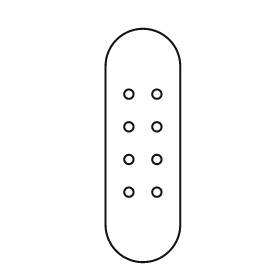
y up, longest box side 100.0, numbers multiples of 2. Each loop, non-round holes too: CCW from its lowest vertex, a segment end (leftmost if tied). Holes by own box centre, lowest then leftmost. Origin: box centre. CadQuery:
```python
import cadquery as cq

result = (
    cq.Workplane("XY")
    .moveTo(-16.0, -34.0)
    .threePointArc((0.0, -50.0), (16.0, -34.0))
    .lineTo(16.0, 34.0)
    .threePointArc((0.0, 50.0), (-16.0, 34.0))
    .close()
    .moveTo(-6.0, -20.0)
    .circle(2.0)
    .moveTo(6.0, -20.0)
    .circle(2.0)
    .moveTo(-6.0, -6.0)
    .circle(2.0)
    .moveTo(6.0, -6.0)
    .circle(2.0)
    .moveTo(-6.0, 8.0)
    .circle(2.0)
    .moveTo(6.0, 8.0)
    .circle(2.0)
    .moveTo(-6.0, 22.0)
    .circle(2.0)
    .moveTo(6.0, 22.0)
    .circle(2.0)
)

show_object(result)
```